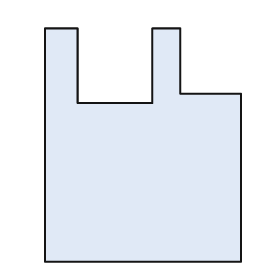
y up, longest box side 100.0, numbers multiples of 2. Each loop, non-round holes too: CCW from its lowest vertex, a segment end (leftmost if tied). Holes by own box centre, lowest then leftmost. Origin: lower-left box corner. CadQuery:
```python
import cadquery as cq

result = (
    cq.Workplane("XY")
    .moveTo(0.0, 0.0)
    .lineTo(84.0, 0.0)
    .lineTo(84.0, 72.0)
    .lineTo(58.0, 72.0)
    .lineTo(58.0, 100.0)
    .lineTo(46.0, 100.0)
    .lineTo(46.0, 68.0)
    .lineTo(14.0, 68.0)
    .lineTo(14.0, 100.0)
    .lineTo(0.0, 100.0)
    .close()
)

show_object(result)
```